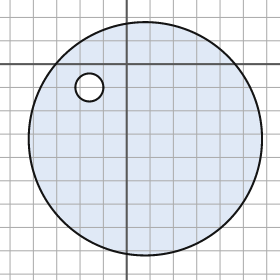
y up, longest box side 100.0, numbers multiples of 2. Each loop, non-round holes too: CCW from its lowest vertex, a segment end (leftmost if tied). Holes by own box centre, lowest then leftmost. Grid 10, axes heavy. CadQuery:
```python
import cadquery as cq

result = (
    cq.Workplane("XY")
    .moveTo(8.0, -32.0)
    .circle(50.0)
    .moveTo(-16.0, -10.0)
    .circle(6.0)
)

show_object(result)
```